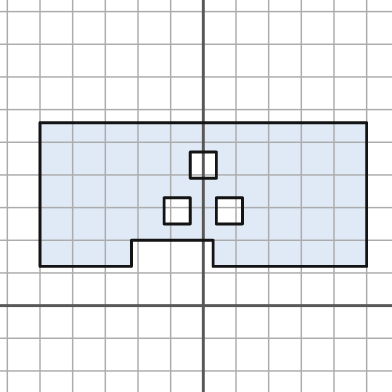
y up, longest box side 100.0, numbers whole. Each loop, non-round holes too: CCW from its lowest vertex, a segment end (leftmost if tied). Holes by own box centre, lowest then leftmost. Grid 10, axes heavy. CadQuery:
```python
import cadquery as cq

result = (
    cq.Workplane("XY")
    .moveTo(-50.0, 12.0)
    .lineTo(-22.0, 12.0)
    .lineTo(-22.0, 20.0)
    .lineTo(3.0, 20.0)
    .lineTo(3.0, 12.0)
    .lineTo(50.0, 12.0)
    .lineTo(50.0, 56.0)
    .lineTo(-50.0, 56.0)
    .close()
    .moveTo(-12.0, 25.0)
    .lineTo(-4.0, 25.0)
    .lineTo(-4.0, 33.0)
    .lineTo(-12.0, 33.0)
    .close()
    .moveTo(4.0, 25.0)
    .lineTo(12.0, 25.0)
    .lineTo(12.0, 33.0)
    .lineTo(4.0, 33.0)
    .close()
    .moveTo(-4.0, 39.0)
    .lineTo(4.0, 39.0)
    .lineTo(4.0, 47.0)
    .lineTo(-4.0, 47.0)
    .close()
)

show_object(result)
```